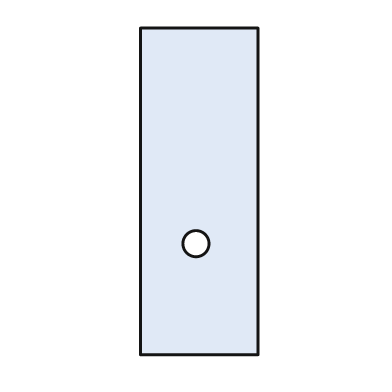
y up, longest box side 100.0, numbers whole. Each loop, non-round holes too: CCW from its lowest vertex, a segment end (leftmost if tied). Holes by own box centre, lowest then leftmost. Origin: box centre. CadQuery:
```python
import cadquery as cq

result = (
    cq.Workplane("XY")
    .moveTo(-18.0, -50.0)
    .lineTo(18.0, -50.0)
    .lineTo(18.0, 50.0)
    .lineTo(-18.0, 50.0)
    .close()
    .moveTo(-1.0, -16.0)
    .circle(4.0)
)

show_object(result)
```